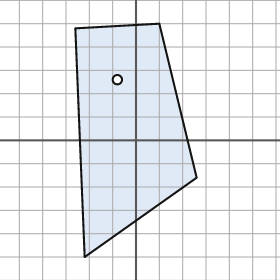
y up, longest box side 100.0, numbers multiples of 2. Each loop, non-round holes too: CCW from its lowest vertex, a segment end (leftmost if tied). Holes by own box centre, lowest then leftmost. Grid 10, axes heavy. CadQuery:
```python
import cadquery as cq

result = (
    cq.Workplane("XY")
    .moveTo(-22.0, -50.0)
    .lineTo(26.0, -16.0)
    .lineTo(10.0, 50.0)
    .lineTo(-26.0, 48.0)
    .close()
    .moveTo(-8.0, 26.0)
    .circle(2.0)
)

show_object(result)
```